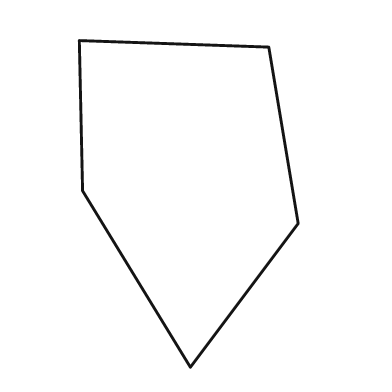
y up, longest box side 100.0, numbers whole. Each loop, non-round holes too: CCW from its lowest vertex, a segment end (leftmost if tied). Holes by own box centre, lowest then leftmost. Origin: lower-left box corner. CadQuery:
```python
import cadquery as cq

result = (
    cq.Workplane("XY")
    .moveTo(34.0, 0.0)
    .lineTo(67.0, 44.0)
    .lineTo(58.0, 98.0)
    .lineTo(0.0, 100.0)
    .lineTo(1.0, 54.0)
    .close()
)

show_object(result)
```